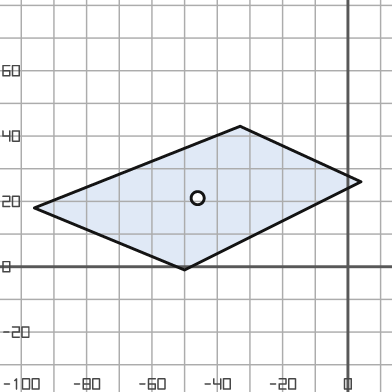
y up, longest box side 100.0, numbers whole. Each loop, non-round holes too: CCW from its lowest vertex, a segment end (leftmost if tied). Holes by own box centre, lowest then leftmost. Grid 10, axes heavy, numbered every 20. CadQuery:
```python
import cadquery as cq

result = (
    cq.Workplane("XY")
    .moveTo(-50.0, -1.0)
    .lineTo(4.0, 26.0)
    .lineTo(-33.0, 43.0)
    .lineTo(-96.0, 18.0)
    .close()
    .moveTo(-46.0, 21.0)
    .circle(2.0)
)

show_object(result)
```